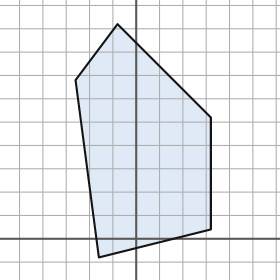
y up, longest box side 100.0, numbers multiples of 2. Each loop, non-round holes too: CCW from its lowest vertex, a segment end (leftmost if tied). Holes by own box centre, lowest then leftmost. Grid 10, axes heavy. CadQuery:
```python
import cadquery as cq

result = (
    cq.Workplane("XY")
    .moveTo(-16.0, -8.0)
    .lineTo(32.0, 4.0)
    .lineTo(32.0, 52.0)
    .lineTo(-8.0, 92.0)
    .lineTo(-26.0, 68.0)
    .close()
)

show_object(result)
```